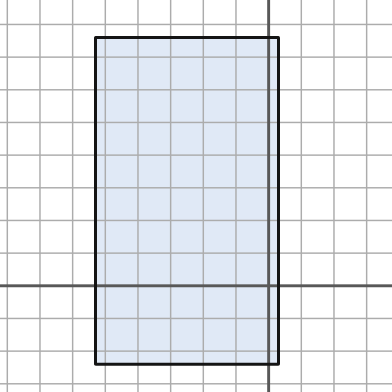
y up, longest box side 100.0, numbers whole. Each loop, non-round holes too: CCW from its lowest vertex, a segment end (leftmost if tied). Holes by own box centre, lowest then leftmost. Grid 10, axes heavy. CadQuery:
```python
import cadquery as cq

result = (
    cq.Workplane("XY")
    .moveTo(-53.0, -24.0)
    .lineTo(3.0, -24.0)
    .lineTo(3.0, 76.0)
    .lineTo(-53.0, 76.0)
    .close()
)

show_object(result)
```